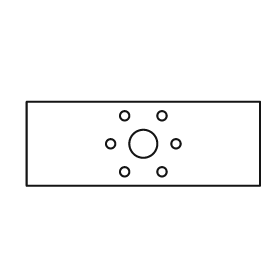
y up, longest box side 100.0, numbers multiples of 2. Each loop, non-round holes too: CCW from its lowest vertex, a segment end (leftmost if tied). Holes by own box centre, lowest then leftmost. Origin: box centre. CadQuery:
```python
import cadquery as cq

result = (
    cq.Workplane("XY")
    .moveTo(-50.0, -18.0)
    .lineTo(50.0, -18.0)
    .lineTo(50.0, 18.0)
    .lineTo(-50.0, 18.0)
    .close()
    .moveTo(-8.0, -12.0)
    .circle(2.0)
    .moveTo(8.0, -12.0)
    .circle(2.0)
    .moveTo(-14.0, 0.0)
    .circle(2.0)
    .moveTo(0.0, 0.0)
    .circle(6.0)
    .moveTo(14.0, 0.0)
    .circle(2.0)
    .moveTo(-8.0, 12.0)
    .circle(2.0)
    .moveTo(8.0, 12.0)
    .circle(2.0)
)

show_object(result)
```